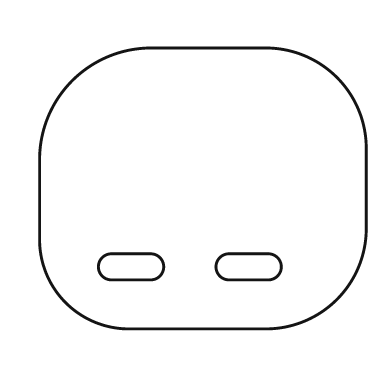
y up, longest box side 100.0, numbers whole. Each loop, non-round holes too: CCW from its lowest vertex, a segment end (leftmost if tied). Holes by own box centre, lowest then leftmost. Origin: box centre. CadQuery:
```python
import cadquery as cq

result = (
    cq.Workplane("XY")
    .moveTo(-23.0, -43.0)
    .lineTo(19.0, -43.0)
    .threePointArc((41.0, -34.0), (50.0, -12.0))
    .lineTo(50.0, 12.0)
    .threePointArc((41.0, 34.0), (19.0, 43.0))
    .lineTo(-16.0, 43.0)
    .threePointArc((-40.0, 33.0), (-50.0, 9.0))
    .lineTo(-50.0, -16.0)
    .threePointArc((-42.0, -35.0), (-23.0, -43.0))
    .close()
    .moveTo(-28.0, -28.0)
    .lineTo(-16.0, -28.0)
    .threePointArc((-12.0, -24.0), (-16.0, -20.0))
    .lineTo(-28.0, -20.0)
    .threePointArc((-32.0, -24.0), (-28.0, -28.0))
    .close()
    .moveTo(8.0, -28.0)
    .lineTo(20.0, -28.0)
    .threePointArc((24.0, -24.0), (20.0, -20.0))
    .lineTo(8.0, -20.0)
    .threePointArc((4.0, -24.0), (8.0, -28.0))
    .close()
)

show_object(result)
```